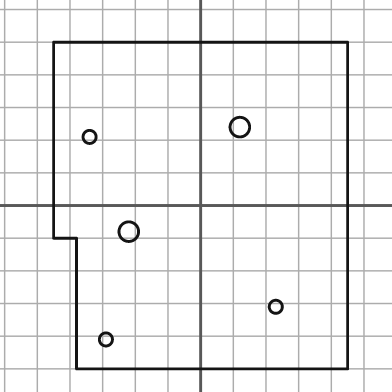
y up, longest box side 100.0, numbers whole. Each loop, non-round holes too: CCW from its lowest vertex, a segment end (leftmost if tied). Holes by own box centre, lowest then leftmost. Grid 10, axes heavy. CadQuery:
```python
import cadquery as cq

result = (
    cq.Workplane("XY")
    .moveTo(-38.0, -50.0)
    .lineTo(45.0, -50.0)
    .lineTo(45.0, 50.0)
    .lineTo(-45.0, 50.0)
    .lineTo(-45.0, -10.0)
    .lineTo(-38.0, -10.0)
    .close()
    .moveTo(-29.0, -41.0)
    .circle(2.0)
    .moveTo(23.0, -31.0)
    .circle(2.0)
    .moveTo(-22.0, -8.0)
    .circle(3.0)
    .moveTo(-34.0, 21.0)
    .circle(2.0)
    .moveTo(12.0, 24.0)
    .circle(3.0)
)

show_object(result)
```